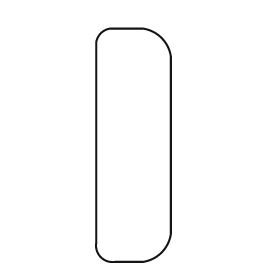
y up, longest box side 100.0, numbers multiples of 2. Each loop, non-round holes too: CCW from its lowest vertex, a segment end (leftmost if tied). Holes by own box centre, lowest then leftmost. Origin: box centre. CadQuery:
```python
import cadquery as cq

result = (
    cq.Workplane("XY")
    .moveTo(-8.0, -50.0)
    .lineTo(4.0, -50.0)
    .threePointArc((12.0, -46.0), (16.0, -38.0))
    .lineTo(16.0, 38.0)
    .threePointArc((12.0, 46.0), (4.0, 50.0))
    .lineTo(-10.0, 50.0)
    .threePointArc((-14.0, 48.0), (-16.0, 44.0))
    .lineTo(-16.0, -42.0)
    .threePointArc((-14.0, -48.0), (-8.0, -50.0))
    .close()
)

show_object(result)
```